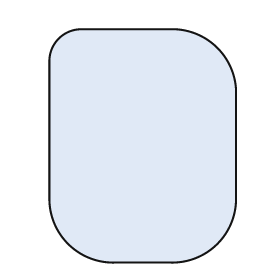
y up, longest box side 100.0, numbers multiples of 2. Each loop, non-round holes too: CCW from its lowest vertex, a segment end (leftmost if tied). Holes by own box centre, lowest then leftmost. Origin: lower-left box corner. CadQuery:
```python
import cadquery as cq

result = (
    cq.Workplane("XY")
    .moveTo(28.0, 0.0)
    .lineTo(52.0, 0.0)
    .threePointArc((72.0, 8.0), (80.0, 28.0))
    .lineTo(80.0, 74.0)
    .threePointArc((72.0, 92.0), (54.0, 100.0))
    .lineTo(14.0, 100.0)
    .threePointArc((4.0, 96.0), (0.0, 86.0))
    .lineTo(0.0, 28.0)
    .threePointArc((8.0, 8.0), (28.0, 0.0))
    .close()
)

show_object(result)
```